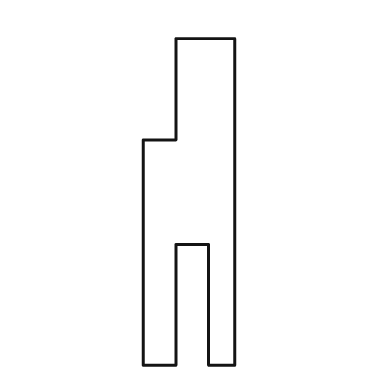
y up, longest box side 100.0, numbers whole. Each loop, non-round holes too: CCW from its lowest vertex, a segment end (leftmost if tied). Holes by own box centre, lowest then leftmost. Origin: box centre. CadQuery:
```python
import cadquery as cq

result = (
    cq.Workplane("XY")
    .moveTo(-14.0, -50.0)
    .lineTo(-4.0, -50.0)
    .lineTo(-4.0, -13.0)
    .lineTo(6.0, -13.0)
    .lineTo(6.0, -50.0)
    .lineTo(14.0, -50.0)
    .lineTo(14.0, 50.0)
    .lineTo(-4.0, 50.0)
    .lineTo(-4.0, 19.0)
    .lineTo(-14.0, 19.0)
    .close()
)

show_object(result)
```